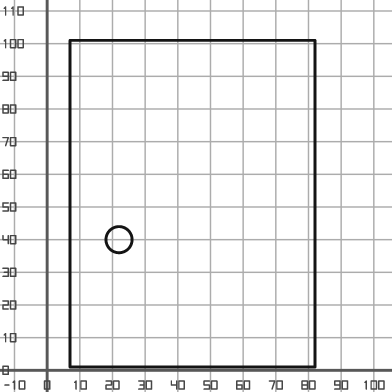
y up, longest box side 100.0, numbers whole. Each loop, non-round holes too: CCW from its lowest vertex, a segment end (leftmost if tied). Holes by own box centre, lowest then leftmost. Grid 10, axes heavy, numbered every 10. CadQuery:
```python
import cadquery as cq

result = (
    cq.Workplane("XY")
    .moveTo(7.0, 1.0)
    .lineTo(82.0, 1.0)
    .lineTo(82.0, 101.0)
    .lineTo(7.0, 101.0)
    .close()
    .moveTo(22.0, 40.0)
    .circle(4.0)
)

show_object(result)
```